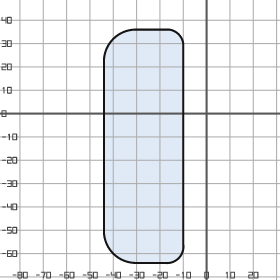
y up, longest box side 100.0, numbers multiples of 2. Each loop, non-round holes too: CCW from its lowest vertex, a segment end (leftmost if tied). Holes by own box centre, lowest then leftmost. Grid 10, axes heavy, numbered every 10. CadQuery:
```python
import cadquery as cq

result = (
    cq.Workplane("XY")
    .moveTo(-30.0, -64.0)
    .lineTo(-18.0, -64.0)
    .threePointArc((-12.0, -62.0), (-10.0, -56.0))
    .lineTo(-10.0, 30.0)
    .threePointArc((-12.0, 34.0), (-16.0, 36.0))
    .lineTo(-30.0, 36.0)
    .threePointArc((-40.0, 32.0), (-44.0, 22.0))
    .lineTo(-44.0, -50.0)
    .threePointArc((-40.0, -60.0), (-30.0, -64.0))
    .close()
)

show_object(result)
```